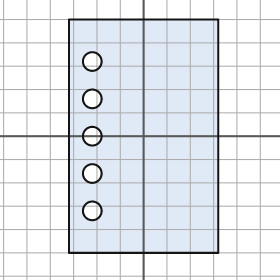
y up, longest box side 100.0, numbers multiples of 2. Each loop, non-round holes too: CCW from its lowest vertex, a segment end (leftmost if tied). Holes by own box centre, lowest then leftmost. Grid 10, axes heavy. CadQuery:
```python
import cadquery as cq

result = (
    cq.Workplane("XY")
    .moveTo(-32.0, -50.0)
    .lineTo(32.0, -50.0)
    .lineTo(32.0, 50.0)
    .lineTo(-32.0, 50.0)
    .close()
    .moveTo(-22.0, -32.0)
    .circle(4.0)
    .moveTo(-22.0, -16.0)
    .circle(4.0)
    .moveTo(-22.0, 0.0)
    .circle(4.0)
    .moveTo(-22.0, 16.0)
    .circle(4.0)
    .moveTo(-22.0, 32.0)
    .circle(4.0)
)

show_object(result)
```